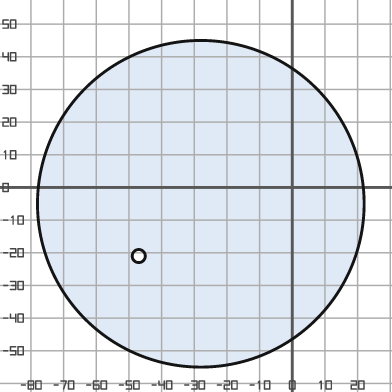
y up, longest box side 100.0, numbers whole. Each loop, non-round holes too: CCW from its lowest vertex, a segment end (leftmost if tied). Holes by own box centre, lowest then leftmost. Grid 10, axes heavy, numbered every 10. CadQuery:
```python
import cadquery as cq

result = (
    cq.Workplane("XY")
    .moveTo(-28.0, -5.0)
    .circle(50.0)
    .moveTo(-47.0, -21.0)
    .circle(2.0)
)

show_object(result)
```